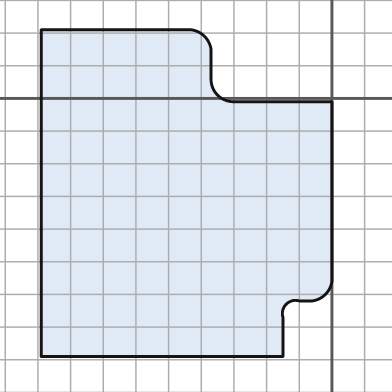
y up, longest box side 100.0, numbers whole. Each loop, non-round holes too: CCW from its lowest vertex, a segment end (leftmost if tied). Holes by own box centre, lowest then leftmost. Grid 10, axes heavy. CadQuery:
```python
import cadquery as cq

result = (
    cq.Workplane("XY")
    .moveTo(-89.0, -79.0)
    .lineTo(-15.0, -79.0)
    .lineTo(-15.0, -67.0)
    .threePointArc((-14.0, -63.0), (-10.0, -62.0))
    .lineTo(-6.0, -62.0)
    .threePointArc((-2.0, -60.0), (0.0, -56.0))
    .lineTo(0.0, -1.0)
    .lineTo(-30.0, -1.0)
    .threePointArc((-35.0, 1.0), (-37.0, 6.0))
    .lineTo(-37.0, 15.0)
    .threePointArc((-39.0, 19.0), (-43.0, 21.0))
    .lineTo(-89.0, 21.0)
    .close()
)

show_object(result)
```